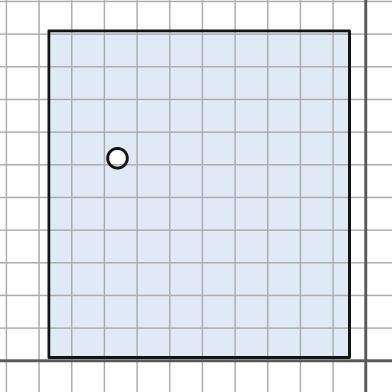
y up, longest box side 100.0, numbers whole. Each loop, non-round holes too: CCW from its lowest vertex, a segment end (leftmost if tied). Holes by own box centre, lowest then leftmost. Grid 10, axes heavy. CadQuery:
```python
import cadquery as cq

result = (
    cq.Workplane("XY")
    .moveTo(-97.0, 1.0)
    .lineTo(-5.0, 1.0)
    .lineTo(-5.0, 101.0)
    .lineTo(-97.0, 101.0)
    .close()
    .moveTo(-76.0, 62.0)
    .circle(3.0)
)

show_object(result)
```